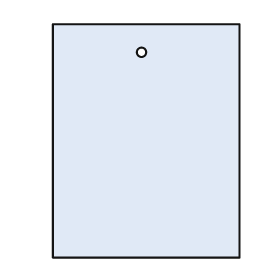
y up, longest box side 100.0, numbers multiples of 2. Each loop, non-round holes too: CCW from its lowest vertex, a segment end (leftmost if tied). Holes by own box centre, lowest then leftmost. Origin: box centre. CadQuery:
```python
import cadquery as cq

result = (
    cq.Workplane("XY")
    .moveTo(-40.0, -50.0)
    .lineTo(40.0, -50.0)
    .lineTo(40.0, 50.0)
    .lineTo(-40.0, 50.0)
    .close()
    .moveTo(-2.0, 38.0)
    .circle(2.0)
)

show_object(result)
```